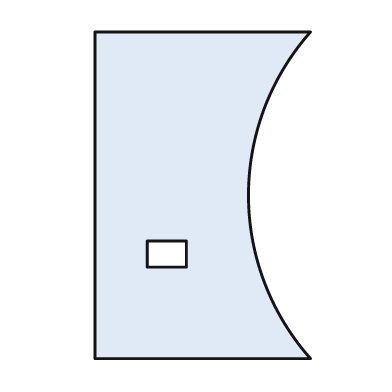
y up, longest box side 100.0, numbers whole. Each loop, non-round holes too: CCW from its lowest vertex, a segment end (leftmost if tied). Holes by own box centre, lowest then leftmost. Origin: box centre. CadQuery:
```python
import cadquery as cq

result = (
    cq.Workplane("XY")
    .moveTo(-33.0, -50.0)
    .lineTo(33.0, -50.0)
    .threePointArc((14.0, 0.0), (33.0, 50.0))
    .lineTo(-33.0, 50.0)
    .close()
    .moveTo(-17.0, -22.0)
    .lineTo(-5.0, -22.0)
    .lineTo(-5.0, -14.0)
    .lineTo(-17.0, -14.0)
    .close()
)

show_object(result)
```